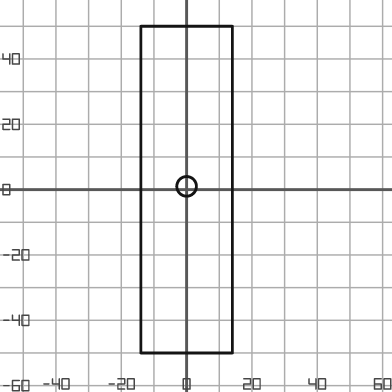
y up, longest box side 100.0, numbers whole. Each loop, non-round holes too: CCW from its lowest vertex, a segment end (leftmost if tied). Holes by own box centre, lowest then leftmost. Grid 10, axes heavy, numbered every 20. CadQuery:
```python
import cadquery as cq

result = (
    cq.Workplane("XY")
    .moveTo(-14.0, -50.0)
    .lineTo(14.0, -50.0)
    .lineTo(14.0, 50.0)
    .lineTo(-14.0, 50.0)
    .close()
    .moveTo(0.0, 1.0)
    .circle(3.0)
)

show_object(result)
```